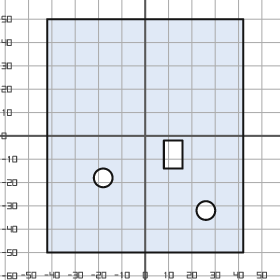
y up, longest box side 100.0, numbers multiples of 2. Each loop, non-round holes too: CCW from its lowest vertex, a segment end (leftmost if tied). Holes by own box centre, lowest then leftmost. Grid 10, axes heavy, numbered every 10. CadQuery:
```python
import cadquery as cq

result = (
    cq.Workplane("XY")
    .moveTo(-42.0, -50.0)
    .lineTo(42.0, -50.0)
    .lineTo(42.0, 50.0)
    .lineTo(-42.0, 50.0)
    .close()
    .moveTo(26.0, -32.0)
    .circle(4.0)
    .moveTo(-18.0, -18.0)
    .circle(4.0)
    .moveTo(8.0, -14.0)
    .lineTo(16.0, -14.0)
    .lineTo(16.0, -2.0)
    .lineTo(8.0, -2.0)
    .close()
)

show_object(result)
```